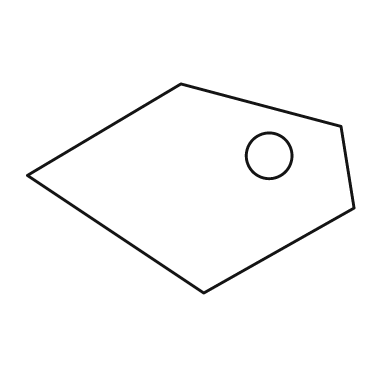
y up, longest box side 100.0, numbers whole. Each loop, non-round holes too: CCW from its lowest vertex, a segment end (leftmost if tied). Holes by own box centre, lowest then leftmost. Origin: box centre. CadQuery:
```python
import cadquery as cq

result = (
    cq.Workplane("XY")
    .moveTo(4.0, -32.0)
    .lineTo(50.0, -6.0)
    .lineTo(46.0, 19.0)
    .lineTo(-3.0, 32.0)
    .lineTo(-50.0, 4.0)
    .close()
    .moveTo(24.0, 10.0)
    .circle(7.0)
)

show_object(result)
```